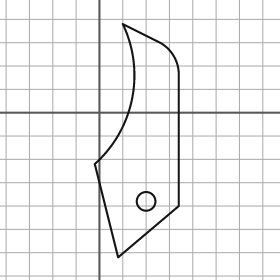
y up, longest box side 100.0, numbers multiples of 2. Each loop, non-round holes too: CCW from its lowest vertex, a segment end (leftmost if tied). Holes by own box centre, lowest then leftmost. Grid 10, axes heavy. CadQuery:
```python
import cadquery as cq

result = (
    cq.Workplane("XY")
    .moveTo(8.0, -62.0)
    .lineTo(34.0, -40.0)
    .lineTo(34.0, 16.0)
    .threePointArc((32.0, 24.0), (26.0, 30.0))
    .lineTo(10.0, 38.0)
    .threePointArc((14.0, 6.0), (-2.0, -22.0))
    .close()
    .moveTo(20.0, -38.0)
    .circle(4.0)
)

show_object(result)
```